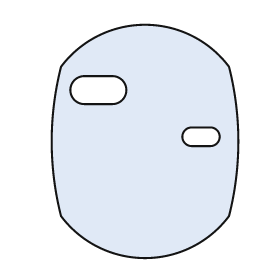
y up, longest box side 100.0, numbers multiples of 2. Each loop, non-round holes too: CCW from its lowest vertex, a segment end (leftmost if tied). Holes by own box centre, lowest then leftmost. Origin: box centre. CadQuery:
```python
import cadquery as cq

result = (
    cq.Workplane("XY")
    .moveTo(-36.0, -32.0)
    .threePointArc((0.0, -50.0), (36.0, -32.0))
    .threePointArc((40.0, 0.0), (36.0, 32.0))
    .threePointArc((0.0, 50.0), (-36.0, 32.0))
    .threePointArc((-40.0, 0.0), (-36.0, -32.0))
    .close()
    .moveTo(20.0, -2.0)
    .lineTo(28.0, -2.0)
    .threePointArc((32.0, 2.0), (28.0, 6.0))
    .lineTo(20.0, 6.0)
    .threePointArc((16.0, 2.0), (20.0, -2.0))
    .close()
    .moveTo(-26.0, 16.0)
    .lineTo(-14.0, 16.0)
    .threePointArc((-8.0, 22.0), (-14.0, 28.0))
    .lineTo(-26.0, 28.0)
    .threePointArc((-32.0, 22.0), (-26.0, 16.0))
    .close()
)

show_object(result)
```